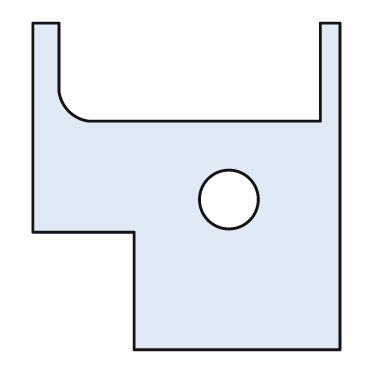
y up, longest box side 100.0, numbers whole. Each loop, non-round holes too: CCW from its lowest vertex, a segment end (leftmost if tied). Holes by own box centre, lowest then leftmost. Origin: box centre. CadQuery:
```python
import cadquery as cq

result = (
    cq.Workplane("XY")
    .moveTo(-16.0, -50.0)
    .lineTo(47.0, -50.0)
    .lineTo(47.0, 50.0)
    .lineTo(41.0, 50.0)
    .lineTo(41.0, 20.0)
    .lineTo(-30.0, 20.0)
    .threePointArc((-36.0, 23.0), (-39.0, 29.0))
    .lineTo(-39.0, 50.0)
    .lineTo(-47.0, 50.0)
    .lineTo(-47.0, -14.0)
    .lineTo(-16.0, -14.0)
    .close()
    .moveTo(13.0, -4.0)
    .circle(9.0)
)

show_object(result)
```